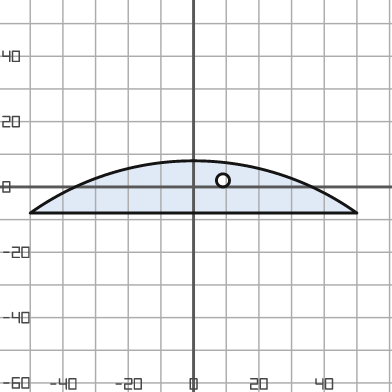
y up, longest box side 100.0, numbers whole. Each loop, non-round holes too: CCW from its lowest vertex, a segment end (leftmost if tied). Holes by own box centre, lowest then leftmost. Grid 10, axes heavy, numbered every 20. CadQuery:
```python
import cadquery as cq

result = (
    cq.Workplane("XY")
    .moveTo(-50.0, -8.0)
    .lineTo(50.0, -8.0)
    .threePointArc((0.0, 8.0), (-50.0, -8.0))
    .close()
    .moveTo(9.0, 2.0)
    .circle(2.0)
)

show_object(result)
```